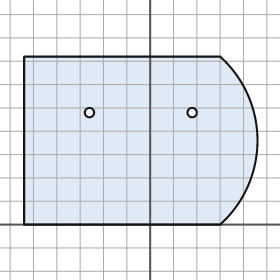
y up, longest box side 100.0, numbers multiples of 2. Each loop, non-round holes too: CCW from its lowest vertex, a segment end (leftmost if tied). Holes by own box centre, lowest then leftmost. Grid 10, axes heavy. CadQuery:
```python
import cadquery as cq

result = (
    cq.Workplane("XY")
    .moveTo(-54.0, 0.0)
    .lineTo(30.0, 0.0)
    .threePointArc((46.0, 36.0), (30.0, 72.0))
    .lineTo(-54.0, 72.0)
    .close()
    .moveTo(-26.0, 48.0)
    .circle(2.0)
    .moveTo(18.0, 48.0)
    .circle(2.0)
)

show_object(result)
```